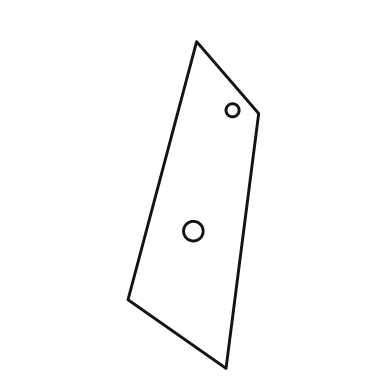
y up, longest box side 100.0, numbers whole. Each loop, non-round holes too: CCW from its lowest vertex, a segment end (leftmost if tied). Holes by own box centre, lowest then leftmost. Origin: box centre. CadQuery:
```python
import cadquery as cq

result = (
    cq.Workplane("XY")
    .moveTo(10.0, -50.0)
    .lineTo(20.0, 28.0)
    .lineTo(1.0, 50.0)
    .lineTo(-20.0, -29.0)
    .close()
    .moveTo(0.0, -8.0)
    .circle(3.0)
    .moveTo(12.0, 29.0)
    .circle(2.0)
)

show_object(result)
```